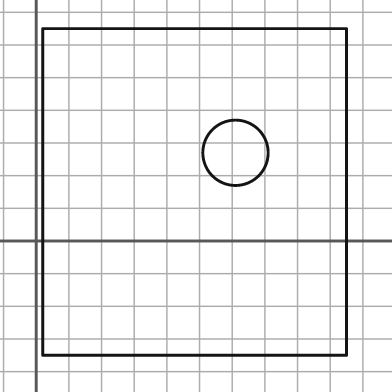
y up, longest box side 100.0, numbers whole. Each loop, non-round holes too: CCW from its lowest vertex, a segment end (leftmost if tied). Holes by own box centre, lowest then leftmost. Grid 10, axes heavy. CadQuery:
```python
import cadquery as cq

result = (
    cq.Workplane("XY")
    .moveTo(2.0, -35.0)
    .lineTo(95.0, -35.0)
    .lineTo(95.0, 65.0)
    .lineTo(2.0, 65.0)
    .close()
    .moveTo(61.0, 27.0)
    .circle(10.0)
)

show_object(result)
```